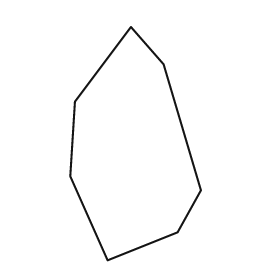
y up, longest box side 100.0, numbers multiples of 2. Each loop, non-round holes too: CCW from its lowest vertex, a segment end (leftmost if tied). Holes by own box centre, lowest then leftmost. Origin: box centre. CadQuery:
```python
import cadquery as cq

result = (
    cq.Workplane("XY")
    .moveTo(-12.0, -50.0)
    .lineTo(18.0, -38.0)
    .lineTo(28.0, -20.0)
    .lineTo(12.0, 34.0)
    .lineTo(-2.0, 50.0)
    .lineTo(-26.0, 18.0)
    .lineTo(-28.0, -14.0)
    .close()
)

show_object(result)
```